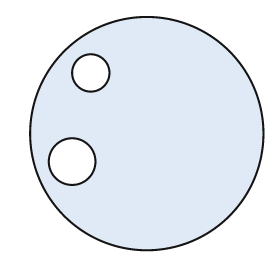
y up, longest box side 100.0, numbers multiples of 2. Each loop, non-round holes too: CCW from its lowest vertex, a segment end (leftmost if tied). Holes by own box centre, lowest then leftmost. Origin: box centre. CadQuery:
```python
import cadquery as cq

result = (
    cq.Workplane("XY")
    .moveTo(0.0, 0.0)
    .circle(50.0)
    .moveTo(-32.0, -12.0)
    .circle(10.0)
    .moveTo(-24.0, 26.0)
    .circle(8.0)
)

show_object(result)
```